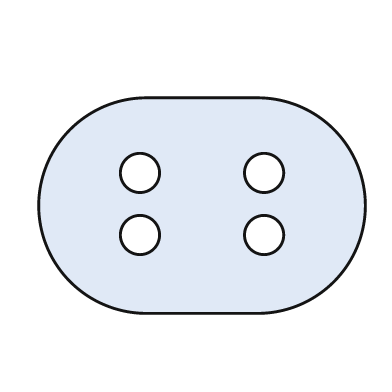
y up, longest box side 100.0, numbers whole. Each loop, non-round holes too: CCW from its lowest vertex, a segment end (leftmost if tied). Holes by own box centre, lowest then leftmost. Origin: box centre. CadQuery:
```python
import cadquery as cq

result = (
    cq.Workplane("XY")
    .moveTo(-17.0, -33.0)
    .lineTo(17.0, -33.0)
    .threePointArc((50.0, 0.0), (17.0, 33.0))
    .lineTo(-17.0, 33.0)
    .threePointArc((-50.0, 0.0), (-17.0, -33.0))
    .close()
    .moveTo(-19.0, -9.0)
    .circle(6.0)
    .moveTo(19.0, -9.0)
    .circle(6.0)
    .moveTo(-19.0, 10.0)
    .circle(6.0)
    .moveTo(19.0, 10.0)
    .circle(6.0)
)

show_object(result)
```